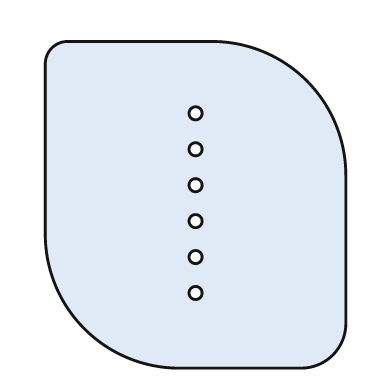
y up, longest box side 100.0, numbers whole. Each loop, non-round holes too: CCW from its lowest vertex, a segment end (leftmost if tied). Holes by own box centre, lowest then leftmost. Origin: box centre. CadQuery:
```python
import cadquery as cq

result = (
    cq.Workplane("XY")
    .moveTo(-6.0, -50.0)
    .lineTo(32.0, -50.0)
    .threePointArc((42.0, -46.0), (46.0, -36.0))
    .lineTo(46.0, 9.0)
    .threePointArc((34.0, 38.0), (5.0, 50.0))
    .lineTo(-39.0, 50.0)
    .threePointArc((-44.0, 48.0), (-46.0, 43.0))
    .lineTo(-46.0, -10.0)
    .threePointArc((-34.0, -38.0), (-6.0, -50.0))
    .close()
    .moveTo(0.0, -27.0)
    .circle(2.0)
    .moveTo(0.0, -16.0)
    .circle(2.0)
    .moveTo(0.0, -5.0)
    .circle(2.0)
    .moveTo(0.0, 6.0)
    .circle(2.0)
    .moveTo(0.0, 17.0)
    .circle(2.0)
    .moveTo(0.0, 28.0)
    .circle(2.0)
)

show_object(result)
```